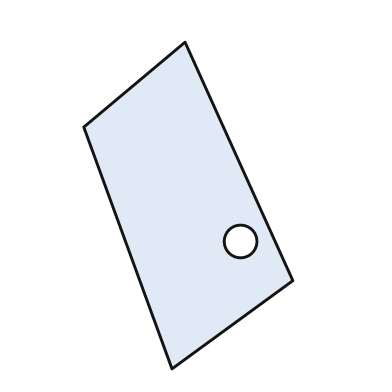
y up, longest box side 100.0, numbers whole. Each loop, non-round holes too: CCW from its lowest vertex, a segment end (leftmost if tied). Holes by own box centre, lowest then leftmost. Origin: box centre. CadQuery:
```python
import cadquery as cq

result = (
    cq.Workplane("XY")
    .moveTo(-5.0, -50.0)
    .lineTo(32.0, -23.0)
    .lineTo(-1.0, 50.0)
    .lineTo(-32.0, 24.0)
    .close()
    .moveTo(16.0, -11.0)
    .circle(5.0)
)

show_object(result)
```